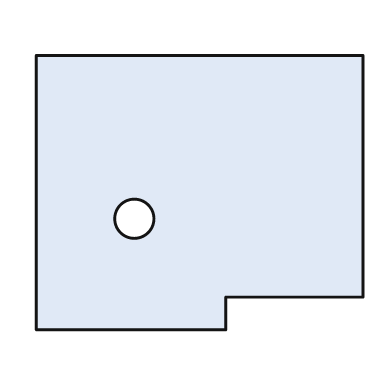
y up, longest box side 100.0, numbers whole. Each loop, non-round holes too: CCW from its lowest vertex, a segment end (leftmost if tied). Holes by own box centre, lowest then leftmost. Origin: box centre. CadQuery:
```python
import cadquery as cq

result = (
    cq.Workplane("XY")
    .moveTo(-50.0, -42.0)
    .lineTo(8.0, -42.0)
    .lineTo(8.0, -32.0)
    .lineTo(50.0, -32.0)
    .lineTo(50.0, 42.0)
    .lineTo(-50.0, 42.0)
    .close()
    .moveTo(-20.0, -8.0)
    .circle(6.0)
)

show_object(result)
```